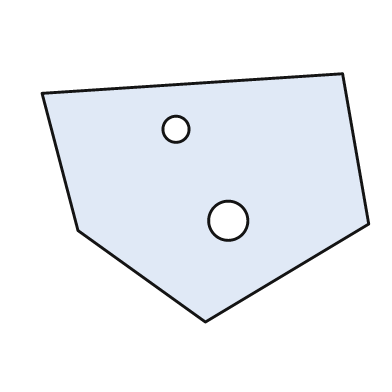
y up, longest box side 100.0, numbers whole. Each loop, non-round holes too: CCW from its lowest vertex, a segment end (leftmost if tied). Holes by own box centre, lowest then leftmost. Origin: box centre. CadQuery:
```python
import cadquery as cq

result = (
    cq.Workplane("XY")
    .moveTo(0.0, -38.0)
    .lineTo(50.0, -8.0)
    .lineTo(42.0, 38.0)
    .lineTo(-50.0, 32.0)
    .lineTo(-39.0, -10.0)
    .close()
    .moveTo(7.0, -7.0)
    .circle(6.0)
    .moveTo(-9.0, 21.0)
    .circle(4.0)
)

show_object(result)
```